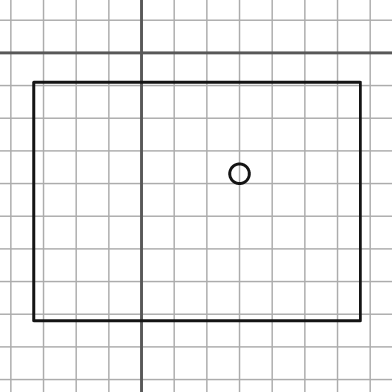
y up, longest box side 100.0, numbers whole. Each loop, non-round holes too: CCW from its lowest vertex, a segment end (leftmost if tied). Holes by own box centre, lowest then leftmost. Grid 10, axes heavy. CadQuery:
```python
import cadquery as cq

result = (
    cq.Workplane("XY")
    .moveTo(-33.0, -82.0)
    .lineTo(67.0, -82.0)
    .lineTo(67.0, -9.0)
    .lineTo(-33.0, -9.0)
    .close()
    .moveTo(30.0, -37.0)
    .circle(3.0)
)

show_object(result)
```